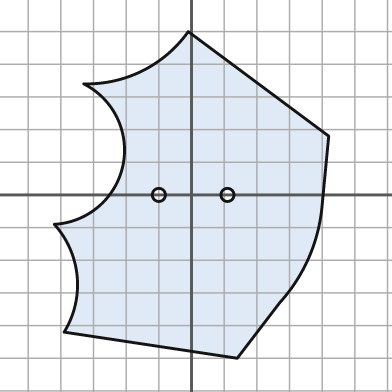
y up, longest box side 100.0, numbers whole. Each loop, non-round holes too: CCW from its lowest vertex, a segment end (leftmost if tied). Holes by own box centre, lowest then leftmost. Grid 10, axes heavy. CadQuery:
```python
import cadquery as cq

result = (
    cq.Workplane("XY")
    .moveTo(14.0, -50.0)
    .lineTo(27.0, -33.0)
    .threePointArc((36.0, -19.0), (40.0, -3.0))
    .lineTo(42.0, 18.0)
    .lineTo(-1.0, 50.0)
    .threePointArc((-15.0, 38.0), (-33.0, 34.0))
    .threePointArc((-21.0, 9.0), (-42.0, -9.0))
    .threePointArc((-35.0, -25.0), (-39.0, -42.0))
    .close()
    .moveTo(-10.0, 0.0)
    .circle(2.0)
    .moveTo(11.0, 0.0)
    .circle(2.0)
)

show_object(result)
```